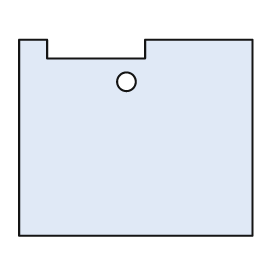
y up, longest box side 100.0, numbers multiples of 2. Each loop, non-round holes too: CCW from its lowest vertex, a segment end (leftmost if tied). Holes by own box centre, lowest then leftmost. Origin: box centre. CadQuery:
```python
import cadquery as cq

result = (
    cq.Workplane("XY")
    .moveTo(-50.0, -42.0)
    .lineTo(50.0, -42.0)
    .lineTo(50.0, 42.0)
    .lineTo(4.0, 42.0)
    .lineTo(4.0, 34.0)
    .lineTo(-38.0, 34.0)
    .lineTo(-38.0, 42.0)
    .lineTo(-50.0, 42.0)
    .close()
    .moveTo(-4.0, 24.0)
    .circle(4.0)
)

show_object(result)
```